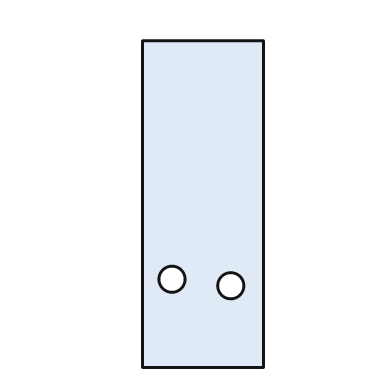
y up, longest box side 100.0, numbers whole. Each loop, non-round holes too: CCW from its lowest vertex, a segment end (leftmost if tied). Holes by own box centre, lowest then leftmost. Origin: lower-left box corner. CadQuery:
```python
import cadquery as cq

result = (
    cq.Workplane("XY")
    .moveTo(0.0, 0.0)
    .lineTo(37.0, 0.0)
    .lineTo(37.0, 100.0)
    .lineTo(0.0, 100.0)
    .close()
    .moveTo(27.0, 25.0)
    .circle(4.0)
    .moveTo(9.0, 27.0)
    .circle(4.0)
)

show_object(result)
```